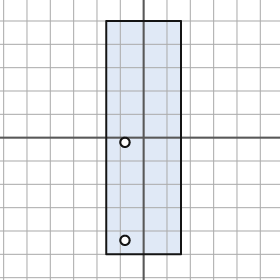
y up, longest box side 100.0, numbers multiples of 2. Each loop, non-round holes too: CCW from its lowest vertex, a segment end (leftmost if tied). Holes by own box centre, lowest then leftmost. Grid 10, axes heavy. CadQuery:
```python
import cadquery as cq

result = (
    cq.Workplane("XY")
    .moveTo(-16.0, -50.0)
    .lineTo(16.0, -50.0)
    .lineTo(16.0, 50.0)
    .lineTo(-16.0, 50.0)
    .close()
    .moveTo(-8.0, -44.0)
    .circle(2.0)
    .moveTo(-8.0, -2.0)
    .circle(2.0)
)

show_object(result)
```